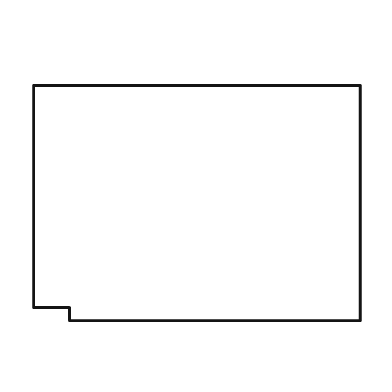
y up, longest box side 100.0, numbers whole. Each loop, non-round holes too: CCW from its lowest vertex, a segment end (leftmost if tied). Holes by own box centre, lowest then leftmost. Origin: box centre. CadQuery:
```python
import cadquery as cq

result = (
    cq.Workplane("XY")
    .moveTo(-39.0, -36.0)
    .lineTo(50.0, -36.0)
    .lineTo(50.0, 36.0)
    .lineTo(-50.0, 36.0)
    .lineTo(-50.0, -32.0)
    .lineTo(-39.0, -32.0)
    .close()
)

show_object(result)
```